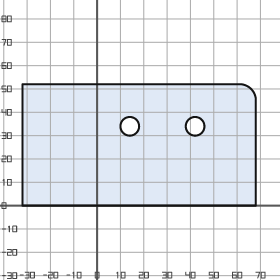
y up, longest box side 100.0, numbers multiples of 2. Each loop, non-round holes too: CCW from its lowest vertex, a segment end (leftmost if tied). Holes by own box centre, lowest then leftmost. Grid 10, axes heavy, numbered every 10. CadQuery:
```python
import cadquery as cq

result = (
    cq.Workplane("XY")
    .moveTo(-32.0, 0.0)
    .lineTo(68.0, 0.0)
    .lineTo(68.0, 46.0)
    .threePointArc((66.0, 50.0), (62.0, 52.0))
    .lineTo(-32.0, 52.0)
    .close()
    .moveTo(14.0, 34.0)
    .circle(4.0)
    .moveTo(42.0, 34.0)
    .circle(4.0)
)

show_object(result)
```